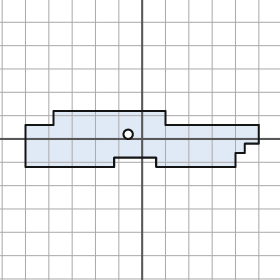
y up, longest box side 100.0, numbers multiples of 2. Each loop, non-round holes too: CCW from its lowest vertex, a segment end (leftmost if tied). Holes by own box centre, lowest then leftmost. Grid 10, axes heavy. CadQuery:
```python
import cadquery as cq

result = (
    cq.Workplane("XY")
    .moveTo(-50.0, -12.0)
    .lineTo(-12.0, -12.0)
    .lineTo(-12.0, -8.0)
    .lineTo(6.0, -8.0)
    .lineTo(6.0, -12.0)
    .lineTo(40.0, -12.0)
    .lineTo(40.0, -6.0)
    .lineTo(44.0, -6.0)
    .lineTo(44.0, -2.0)
    .lineTo(50.0, -2.0)
    .lineTo(50.0, 6.0)
    .lineTo(10.0, 6.0)
    .lineTo(10.0, 12.0)
    .lineTo(-38.0, 12.0)
    .lineTo(-38.0, 6.0)
    .lineTo(-50.0, 6.0)
    .close()
    .moveTo(-6.0, 2.0)
    .circle(2.0)
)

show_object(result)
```